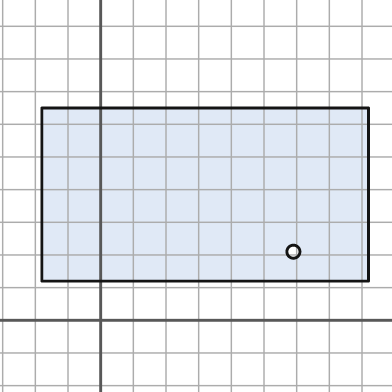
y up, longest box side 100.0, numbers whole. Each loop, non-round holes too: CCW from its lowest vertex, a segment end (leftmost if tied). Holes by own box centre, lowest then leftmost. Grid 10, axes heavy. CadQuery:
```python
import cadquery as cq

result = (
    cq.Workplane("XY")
    .moveTo(-18.0, 12.0)
    .lineTo(82.0, 12.0)
    .lineTo(82.0, 65.0)
    .lineTo(-18.0, 65.0)
    .close()
    .moveTo(59.0, 21.0)
    .circle(2.0)
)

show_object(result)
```